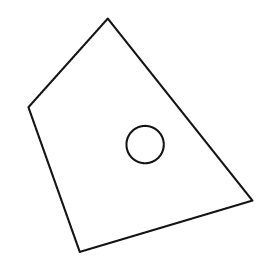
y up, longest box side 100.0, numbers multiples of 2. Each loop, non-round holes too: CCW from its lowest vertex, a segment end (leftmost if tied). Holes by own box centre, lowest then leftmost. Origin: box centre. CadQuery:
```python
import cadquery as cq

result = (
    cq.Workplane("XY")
    .moveTo(-26.0, -50.0)
    .lineTo(48.0, -28.0)
    .lineTo(-14.0, 50.0)
    .lineTo(-48.0, 12.0)
    .close()
    .moveTo(2.0, -4.0)
    .circle(8.0)
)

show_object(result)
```